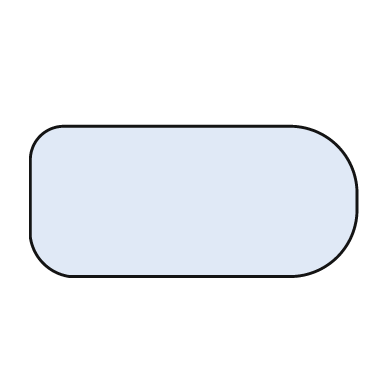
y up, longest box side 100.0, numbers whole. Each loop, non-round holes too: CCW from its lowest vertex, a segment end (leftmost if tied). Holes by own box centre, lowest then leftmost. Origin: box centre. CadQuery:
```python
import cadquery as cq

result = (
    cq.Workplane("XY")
    .moveTo(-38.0, -23.0)
    .lineTo(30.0, -23.0)
    .threePointArc((44.0, -17.0), (50.0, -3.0))
    .lineTo(50.0, 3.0)
    .threePointArc((44.0, 17.0), (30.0, 23.0))
    .lineTo(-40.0, 23.0)
    .threePointArc((-47.0, 20.0), (-50.0, 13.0))
    .lineTo(-50.0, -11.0)
    .threePointArc((-46.0, -19.0), (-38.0, -23.0))
    .close()
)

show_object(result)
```